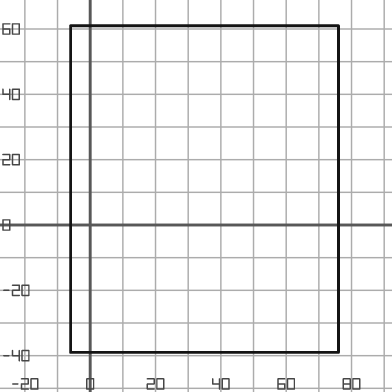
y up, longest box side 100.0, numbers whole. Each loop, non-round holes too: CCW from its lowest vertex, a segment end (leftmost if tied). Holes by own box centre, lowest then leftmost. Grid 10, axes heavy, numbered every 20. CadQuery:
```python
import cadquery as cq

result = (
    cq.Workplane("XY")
    .moveTo(-6.0, -39.0)
    .lineTo(76.0, -39.0)
    .lineTo(76.0, 61.0)
    .lineTo(-6.0, 61.0)
    .close()
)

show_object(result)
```